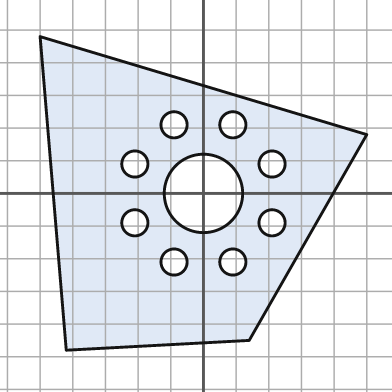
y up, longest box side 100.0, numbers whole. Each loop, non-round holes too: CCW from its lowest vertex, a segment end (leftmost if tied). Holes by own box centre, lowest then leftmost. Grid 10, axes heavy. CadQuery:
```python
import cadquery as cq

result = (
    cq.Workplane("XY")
    .moveTo(-42.0, -48.0)
    .lineTo(14.0, -45.0)
    .lineTo(50.0, 18.0)
    .lineTo(-50.0, 48.0)
    .close()
    .moveTo(-9.0, -21.0)
    .circle(4.0)
    .moveTo(9.0, -21.0)
    .circle(4.0)
    .moveTo(-21.0, -9.0)
    .circle(4.0)
    .moveTo(21.0, -9.0)
    .circle(4.0)
    .moveTo(0.0, 0.0)
    .circle(12.0)
    .moveTo(-21.0, 9.0)
    .circle(4.0)
    .moveTo(21.0, 9.0)
    .circle(4.0)
    .moveTo(-9.0, 21.0)
    .circle(4.0)
    .moveTo(9.0, 21.0)
    .circle(4.0)
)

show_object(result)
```